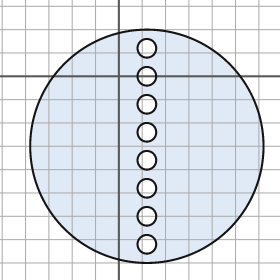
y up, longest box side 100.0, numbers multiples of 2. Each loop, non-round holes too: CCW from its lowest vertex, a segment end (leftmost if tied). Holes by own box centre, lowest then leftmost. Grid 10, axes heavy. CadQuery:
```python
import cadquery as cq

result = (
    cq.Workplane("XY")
    .moveTo(12.0, -30.0)
    .circle(50.0)
    .moveTo(12.0, -72.0)
    .circle(4.0)
    .moveTo(12.0, -60.0)
    .circle(4.0)
    .moveTo(12.0, -48.0)
    .circle(4.0)
    .moveTo(12.0, -36.0)
    .circle(4.0)
    .moveTo(12.0, -24.0)
    .circle(4.0)
    .moveTo(12.0, -12.0)
    .circle(4.0)
    .moveTo(12.0, 0.0)
    .circle(4.0)
    .moveTo(12.0, 12.0)
    .circle(4.0)
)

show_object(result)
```